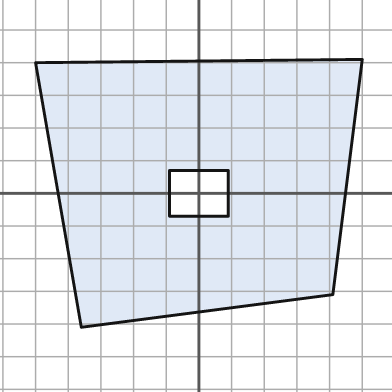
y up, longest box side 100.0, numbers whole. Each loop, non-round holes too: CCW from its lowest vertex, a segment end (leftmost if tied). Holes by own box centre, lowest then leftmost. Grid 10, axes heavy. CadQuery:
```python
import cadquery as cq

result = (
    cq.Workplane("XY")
    .moveTo(-36.0, -41.0)
    .lineTo(41.0, -31.0)
    .lineTo(50.0, 41.0)
    .lineTo(-50.0, 40.0)
    .close()
    .moveTo(-9.0, -7.0)
    .lineTo(9.0, -7.0)
    .lineTo(9.0, 7.0)
    .lineTo(-9.0, 7.0)
    .close()
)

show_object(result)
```